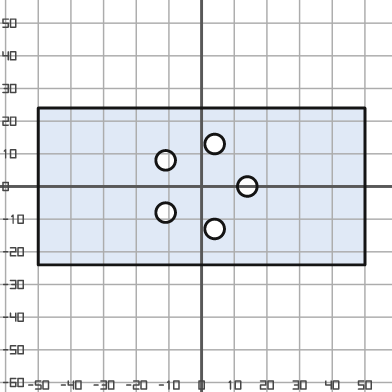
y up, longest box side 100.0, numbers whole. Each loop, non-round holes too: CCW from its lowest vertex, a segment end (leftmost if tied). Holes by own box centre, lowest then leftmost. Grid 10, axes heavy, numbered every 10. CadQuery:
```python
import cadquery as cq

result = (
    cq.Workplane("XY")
    .moveTo(-50.0, -24.0)
    .lineTo(50.0, -24.0)
    .lineTo(50.0, 24.0)
    .lineTo(-50.0, 24.0)
    .close()
    .moveTo(4.0, -13.0)
    .circle(3.0)
    .moveTo(-11.0, -8.0)
    .circle(3.0)
    .moveTo(14.0, 0.0)
    .circle(3.0)
    .moveTo(-11.0, 8.0)
    .circle(3.0)
    .moveTo(4.0, 13.0)
    .circle(3.0)
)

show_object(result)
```